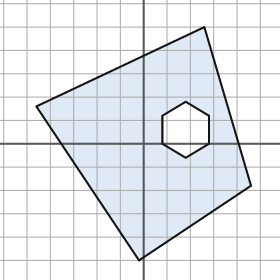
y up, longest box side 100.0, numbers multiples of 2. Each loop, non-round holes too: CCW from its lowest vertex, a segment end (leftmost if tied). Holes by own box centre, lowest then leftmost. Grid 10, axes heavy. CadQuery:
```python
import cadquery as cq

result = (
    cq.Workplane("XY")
    .moveTo(-2.0, -50.0)
    .lineTo(46.0, -18.0)
    .lineTo(26.0, 50.0)
    .lineTo(-46.0, 16.0)
    .close()
    .moveTo(18.0, -6.0)
    .lineTo(28.0, 0.0)
    .lineTo(28.0, 12.0)
    .lineTo(18.0, 18.0)
    .lineTo(8.0, 12.0)
    .lineTo(8.0, 0.0)
    .close()
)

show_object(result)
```